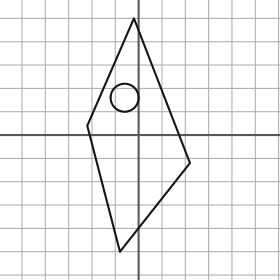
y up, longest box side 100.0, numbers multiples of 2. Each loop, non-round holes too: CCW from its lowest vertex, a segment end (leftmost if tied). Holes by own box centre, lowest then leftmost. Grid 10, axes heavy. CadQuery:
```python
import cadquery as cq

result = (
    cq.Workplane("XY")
    .moveTo(-8.0, -50.0)
    .lineTo(22.0, -12.0)
    .lineTo(-2.0, 50.0)
    .lineTo(-22.0, 4.0)
    .close()
    .moveTo(-6.0, 16.0)
    .circle(6.0)
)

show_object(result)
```